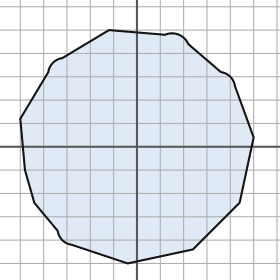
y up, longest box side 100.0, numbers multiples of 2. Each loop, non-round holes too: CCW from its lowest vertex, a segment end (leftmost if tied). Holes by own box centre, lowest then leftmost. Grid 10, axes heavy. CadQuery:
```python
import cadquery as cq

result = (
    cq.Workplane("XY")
    .moveTo(-4.0, -50.0)
    .lineTo(24.0, -44.0)
    .lineTo(44.0, -24.0)
    .lineTo(50.0, 4.0)
    .lineTo(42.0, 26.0)
    .threePointArc((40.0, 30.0), (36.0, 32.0))
    .lineTo(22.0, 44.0)
    .threePointArc((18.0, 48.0), (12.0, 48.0))
    .lineTo(-12.0, 50.0)
    .lineTo(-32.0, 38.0)
    .threePointArc((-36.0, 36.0), (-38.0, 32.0))
    .lineTo(-50.0, 12.0)
    .lineTo(-48.0, -10.0)
    .lineTo(-44.0, -24.0)
    .lineTo(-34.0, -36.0)
    .threePointArc((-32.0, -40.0), (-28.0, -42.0))
    .close()
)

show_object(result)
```